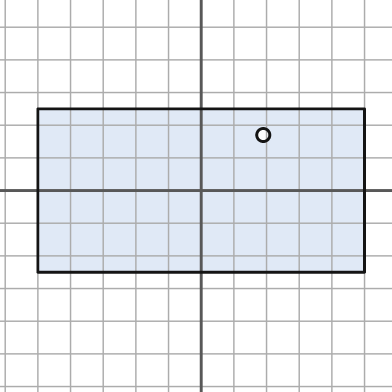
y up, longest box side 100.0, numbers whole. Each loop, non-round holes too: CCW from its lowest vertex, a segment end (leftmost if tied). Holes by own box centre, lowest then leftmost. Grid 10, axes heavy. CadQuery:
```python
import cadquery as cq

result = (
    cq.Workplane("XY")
    .moveTo(-50.0, -25.0)
    .lineTo(50.0, -25.0)
    .lineTo(50.0, 25.0)
    .lineTo(-50.0, 25.0)
    .close()
    .moveTo(19.0, 17.0)
    .circle(2.0)
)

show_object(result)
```